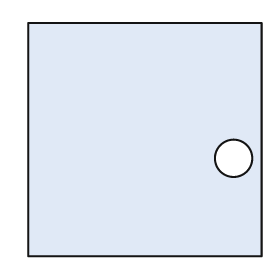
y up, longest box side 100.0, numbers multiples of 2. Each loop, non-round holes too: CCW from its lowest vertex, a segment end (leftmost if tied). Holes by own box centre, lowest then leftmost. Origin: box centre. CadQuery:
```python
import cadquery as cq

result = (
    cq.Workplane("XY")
    .moveTo(-50.0, -50.0)
    .lineTo(50.0, -50.0)
    .lineTo(50.0, 50.0)
    .lineTo(-50.0, 50.0)
    .close()
    .moveTo(38.0, -8.0)
    .circle(8.0)
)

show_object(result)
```